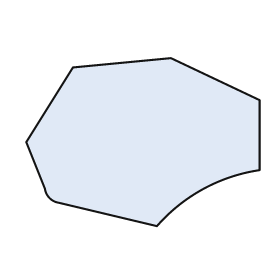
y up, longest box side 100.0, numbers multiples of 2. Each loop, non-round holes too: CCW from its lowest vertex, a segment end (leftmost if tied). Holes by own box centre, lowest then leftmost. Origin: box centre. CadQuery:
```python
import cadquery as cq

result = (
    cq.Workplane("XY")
    .moveTo(6.0, -36.0)
    .threePointArc((26.0, -20.0), (50.0, -12.0))
    .lineTo(50.0, 18.0)
    .lineTo(12.0, 36.0)
    .lineTo(-30.0, 32.0)
    .lineTo(-50.0, 0.0)
    .lineTo(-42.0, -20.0)
    .threePointArc((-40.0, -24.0), (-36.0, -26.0))
    .close()
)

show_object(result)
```